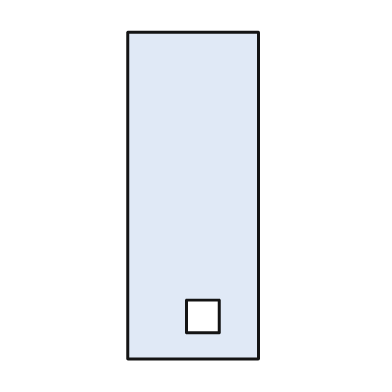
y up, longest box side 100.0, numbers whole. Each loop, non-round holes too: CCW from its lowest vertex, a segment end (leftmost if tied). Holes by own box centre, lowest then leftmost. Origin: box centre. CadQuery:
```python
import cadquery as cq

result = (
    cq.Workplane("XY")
    .moveTo(-20.0, -50.0)
    .lineTo(20.0, -50.0)
    .lineTo(20.0, 50.0)
    .lineTo(-20.0, 50.0)
    .close()
    .moveTo(-2.0, -42.0)
    .lineTo(8.0, -42.0)
    .lineTo(8.0, -32.0)
    .lineTo(-2.0, -32.0)
    .close()
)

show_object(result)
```